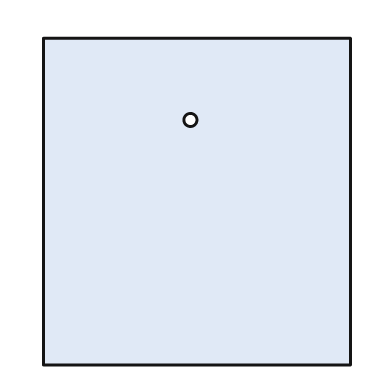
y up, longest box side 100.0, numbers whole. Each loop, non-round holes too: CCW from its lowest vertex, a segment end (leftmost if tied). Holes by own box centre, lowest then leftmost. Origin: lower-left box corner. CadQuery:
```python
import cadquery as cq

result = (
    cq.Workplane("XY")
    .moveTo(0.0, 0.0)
    .lineTo(94.0, 0.0)
    .lineTo(94.0, 100.0)
    .lineTo(0.0, 100.0)
    .close()
    .moveTo(45.0, 75.0)
    .circle(2.0)
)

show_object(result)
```